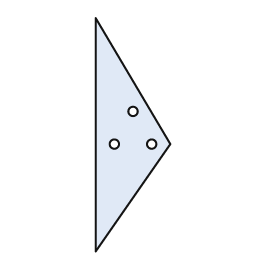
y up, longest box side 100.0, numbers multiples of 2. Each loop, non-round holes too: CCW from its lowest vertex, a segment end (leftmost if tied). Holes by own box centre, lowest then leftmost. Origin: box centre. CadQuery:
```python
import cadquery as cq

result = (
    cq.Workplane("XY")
    .moveTo(-16.0, -50.0)
    .lineTo(16.0, -4.0)
    .lineTo(-16.0, 50.0)
    .close()
    .moveTo(-8.0, -4.0)
    .circle(2.0)
    .moveTo(8.0, -4.0)
    .circle(2.0)
    .moveTo(0.0, 10.0)
    .circle(2.0)
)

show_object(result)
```